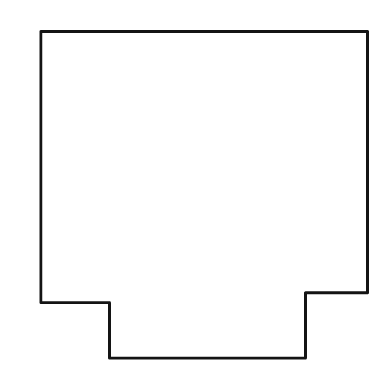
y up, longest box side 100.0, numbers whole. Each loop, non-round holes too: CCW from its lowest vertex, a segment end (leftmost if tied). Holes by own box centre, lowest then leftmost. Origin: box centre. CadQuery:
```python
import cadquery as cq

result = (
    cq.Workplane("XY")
    .moveTo(-29.0, -50.0)
    .lineTo(31.0, -50.0)
    .lineTo(31.0, -30.0)
    .lineTo(50.0, -30.0)
    .lineTo(50.0, 50.0)
    .lineTo(-50.0, 50.0)
    .lineTo(-50.0, -33.0)
    .lineTo(-29.0, -33.0)
    .close()
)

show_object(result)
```